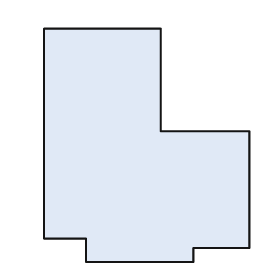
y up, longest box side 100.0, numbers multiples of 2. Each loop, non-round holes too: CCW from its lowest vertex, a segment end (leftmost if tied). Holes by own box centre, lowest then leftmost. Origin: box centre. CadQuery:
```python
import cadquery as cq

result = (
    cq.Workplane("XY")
    .moveTo(-26.0, -50.0)
    .lineTo(20.0, -50.0)
    .lineTo(20.0, -44.0)
    .lineTo(44.0, -44.0)
    .lineTo(44.0, 6.0)
    .lineTo(6.0, 6.0)
    .lineTo(6.0, 50.0)
    .lineTo(-44.0, 50.0)
    .lineTo(-44.0, -40.0)
    .lineTo(-26.0, -40.0)
    .close()
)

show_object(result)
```